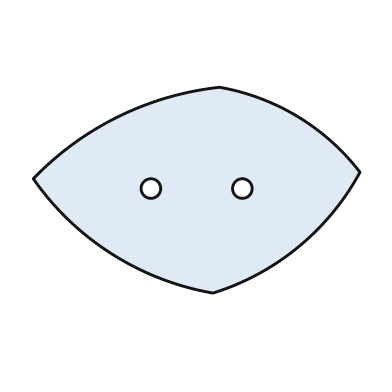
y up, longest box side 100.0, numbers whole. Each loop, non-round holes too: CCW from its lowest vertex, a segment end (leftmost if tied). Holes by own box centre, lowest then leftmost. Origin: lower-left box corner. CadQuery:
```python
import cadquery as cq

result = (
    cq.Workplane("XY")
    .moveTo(55.0, 0.0)
    .threePointArc((81.0, 14.0), (100.0, 37.0))
    .threePointArc((81.0, 54.0), (57.0, 63.0))
    .threePointArc((26.0, 54.0), (0.0, 35.0))
    .threePointArc((24.0, 12.0), (55.0, 0.0))
    .close()
    .moveTo(36.0, 32.0)
    .circle(3.0)
    .moveTo(64.0, 32.0)
    .circle(3.0)
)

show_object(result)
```